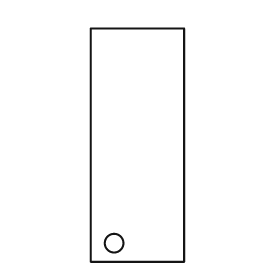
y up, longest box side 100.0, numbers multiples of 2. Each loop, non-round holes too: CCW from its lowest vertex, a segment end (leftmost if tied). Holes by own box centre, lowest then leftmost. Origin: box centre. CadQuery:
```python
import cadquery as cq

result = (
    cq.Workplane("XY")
    .moveTo(-20.0, -50.0)
    .lineTo(20.0, -50.0)
    .lineTo(20.0, 50.0)
    .lineTo(-20.0, 50.0)
    .close()
    .moveTo(-10.0, -42.0)
    .circle(4.0)
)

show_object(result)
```